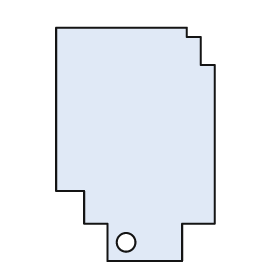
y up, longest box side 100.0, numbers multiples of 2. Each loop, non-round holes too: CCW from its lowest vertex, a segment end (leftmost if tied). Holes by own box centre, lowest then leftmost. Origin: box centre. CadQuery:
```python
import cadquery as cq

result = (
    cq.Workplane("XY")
    .moveTo(-12.0, -50.0)
    .lineTo(20.0, -50.0)
    .lineTo(20.0, -34.0)
    .lineTo(34.0, -34.0)
    .lineTo(34.0, 34.0)
    .lineTo(28.0, 34.0)
    .lineTo(28.0, 46.0)
    .lineTo(22.0, 46.0)
    .lineTo(22.0, 50.0)
    .lineTo(-34.0, 50.0)
    .lineTo(-34.0, -20.0)
    .lineTo(-22.0, -20.0)
    .lineTo(-22.0, -34.0)
    .lineTo(-12.0, -34.0)
    .close()
    .moveTo(-4.0, -42.0)
    .circle(4.0)
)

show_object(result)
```